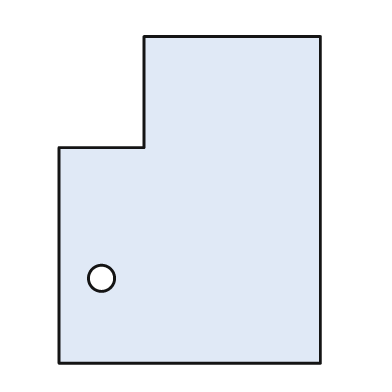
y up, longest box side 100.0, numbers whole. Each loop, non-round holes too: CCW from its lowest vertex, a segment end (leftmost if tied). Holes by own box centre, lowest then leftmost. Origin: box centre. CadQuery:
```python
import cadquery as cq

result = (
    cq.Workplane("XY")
    .moveTo(-40.0, -50.0)
    .lineTo(40.0, -50.0)
    .lineTo(40.0, 50.0)
    .lineTo(-14.0, 50.0)
    .lineTo(-14.0, 16.0)
    .lineTo(-40.0, 16.0)
    .close()
    .moveTo(-27.0, -24.0)
    .circle(4.0)
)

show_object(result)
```